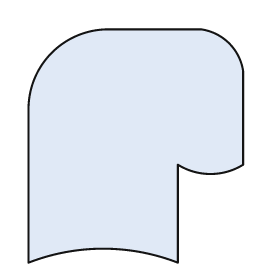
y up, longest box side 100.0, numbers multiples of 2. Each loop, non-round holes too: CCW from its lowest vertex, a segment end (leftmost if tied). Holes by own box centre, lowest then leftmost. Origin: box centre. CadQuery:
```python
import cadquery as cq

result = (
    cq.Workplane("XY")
    .moveTo(-46.0, -50.0)
    .threePointArc((-14.0, -44.0), (18.0, -50.0))
    .lineTo(18.0, -8.0)
    .threePointArc((32.0, -12.0), (46.0, -8.0))
    .lineTo(46.0, 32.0)
    .threePointArc((40.0, 44.0), (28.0, 50.0))
    .lineTo(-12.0, 50.0)
    .threePointArc((-36.0, 40.0), (-46.0, 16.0))
    .close()
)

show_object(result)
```